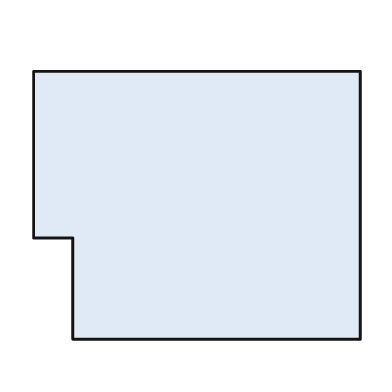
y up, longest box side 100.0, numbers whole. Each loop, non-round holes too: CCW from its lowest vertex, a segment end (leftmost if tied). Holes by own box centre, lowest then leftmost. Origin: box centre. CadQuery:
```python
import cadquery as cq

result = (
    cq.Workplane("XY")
    .moveTo(-38.0, -41.0)
    .lineTo(50.0, -41.0)
    .lineTo(50.0, 41.0)
    .lineTo(-50.0, 41.0)
    .lineTo(-50.0, -10.0)
    .lineTo(-38.0, -10.0)
    .close()
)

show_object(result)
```